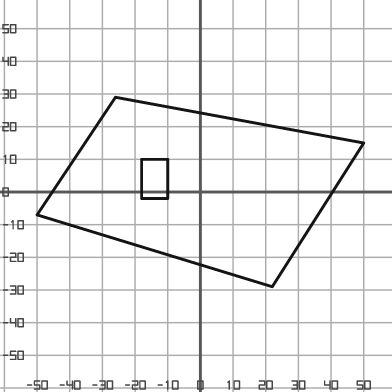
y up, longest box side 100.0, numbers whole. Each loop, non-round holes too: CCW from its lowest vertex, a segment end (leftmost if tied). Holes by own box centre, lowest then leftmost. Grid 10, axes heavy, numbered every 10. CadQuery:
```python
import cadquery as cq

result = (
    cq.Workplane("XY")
    .moveTo(22.0, -29.0)
    .lineTo(50.0, 15.0)
    .lineTo(-26.0, 29.0)
    .lineTo(-50.0, -7.0)
    .close()
    .moveTo(-18.0, -2.0)
    .lineTo(-10.0, -2.0)
    .lineTo(-10.0, 10.0)
    .lineTo(-18.0, 10.0)
    .close()
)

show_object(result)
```